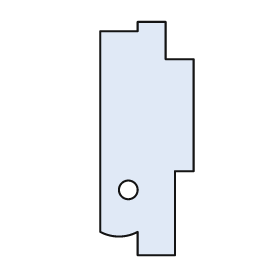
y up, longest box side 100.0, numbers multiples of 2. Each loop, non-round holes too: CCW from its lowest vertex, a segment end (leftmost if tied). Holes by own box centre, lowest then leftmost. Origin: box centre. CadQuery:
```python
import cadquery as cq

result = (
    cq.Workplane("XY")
    .moveTo(-4.0, -50.0)
    .lineTo(12.0, -50.0)
    .lineTo(12.0, -14.0)
    .lineTo(20.0, -14.0)
    .lineTo(20.0, 34.0)
    .lineTo(8.0, 34.0)
    .lineTo(8.0, 50.0)
    .lineTo(-4.0, 50.0)
    .lineTo(-4.0, 46.0)
    .lineTo(-20.0, 46.0)
    .lineTo(-20.0, -40.0)
    .threePointArc((-12.0, -42.0), (-4.0, -40.0))
    .close()
    .moveTo(-8.0, -22.0)
    .circle(4.0)
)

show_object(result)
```